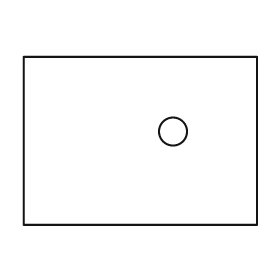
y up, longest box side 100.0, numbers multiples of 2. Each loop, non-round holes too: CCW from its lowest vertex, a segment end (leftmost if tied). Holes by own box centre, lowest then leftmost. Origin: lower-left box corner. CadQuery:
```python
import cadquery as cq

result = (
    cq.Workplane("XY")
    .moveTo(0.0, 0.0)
    .lineTo(100.0, 0.0)
    .lineTo(100.0, 72.0)
    .lineTo(0.0, 72.0)
    .close()
    .moveTo(64.0, 40.0)
    .circle(6.0)
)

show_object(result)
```